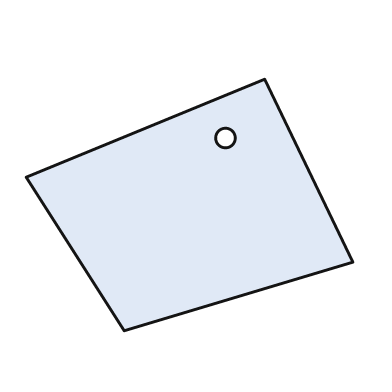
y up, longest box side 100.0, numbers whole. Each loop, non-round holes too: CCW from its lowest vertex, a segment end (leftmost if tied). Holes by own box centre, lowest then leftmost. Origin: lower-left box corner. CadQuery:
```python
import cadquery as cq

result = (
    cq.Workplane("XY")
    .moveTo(30.0, 0.0)
    .lineTo(100.0, 21.0)
    .lineTo(73.0, 77.0)
    .lineTo(0.0, 47.0)
    .close()
    .moveTo(61.0, 59.0)
    .circle(3.0)
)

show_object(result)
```